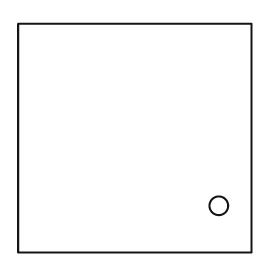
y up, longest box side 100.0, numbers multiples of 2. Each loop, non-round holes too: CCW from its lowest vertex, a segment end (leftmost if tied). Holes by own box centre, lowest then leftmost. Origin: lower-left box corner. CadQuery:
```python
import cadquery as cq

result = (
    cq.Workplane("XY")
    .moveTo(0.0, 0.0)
    .lineTo(100.0, 0.0)
    .lineTo(100.0, 98.0)
    .lineTo(0.0, 98.0)
    .close()
    .moveTo(86.0, 20.0)
    .circle(4.0)
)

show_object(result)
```